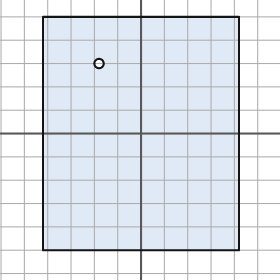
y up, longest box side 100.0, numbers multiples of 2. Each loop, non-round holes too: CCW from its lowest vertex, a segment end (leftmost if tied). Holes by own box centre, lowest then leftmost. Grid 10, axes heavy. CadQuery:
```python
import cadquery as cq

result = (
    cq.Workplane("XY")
    .moveTo(-42.0, -50.0)
    .lineTo(42.0, -50.0)
    .lineTo(42.0, 50.0)
    .lineTo(-42.0, 50.0)
    .close()
    .moveTo(-18.0, 30.0)
    .circle(2.0)
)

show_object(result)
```